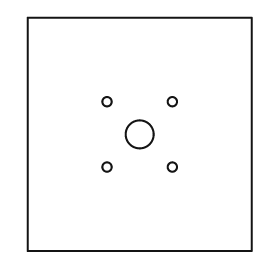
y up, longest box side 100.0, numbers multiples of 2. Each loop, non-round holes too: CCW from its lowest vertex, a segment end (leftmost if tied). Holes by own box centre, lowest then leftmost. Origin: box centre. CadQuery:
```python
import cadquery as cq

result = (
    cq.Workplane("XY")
    .moveTo(-48.0, -50.0)
    .lineTo(48.0, -50.0)
    .lineTo(48.0, 50.0)
    .lineTo(-48.0, 50.0)
    .close()
    .moveTo(-14.0, -14.0)
    .circle(2.0)
    .moveTo(14.0, -14.0)
    .circle(2.0)
    .moveTo(0.0, 0.0)
    .circle(6.0)
    .moveTo(-14.0, 14.0)
    .circle(2.0)
    .moveTo(14.0, 14.0)
    .circle(2.0)
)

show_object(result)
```